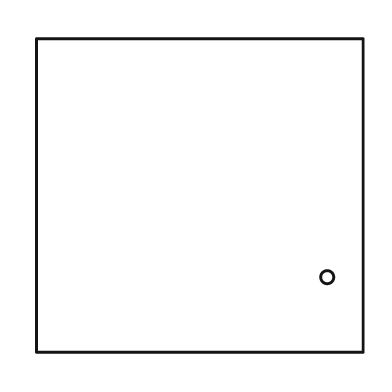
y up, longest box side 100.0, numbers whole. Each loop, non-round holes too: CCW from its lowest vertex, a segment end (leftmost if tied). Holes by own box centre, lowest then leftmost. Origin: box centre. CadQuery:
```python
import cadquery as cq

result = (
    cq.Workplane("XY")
    .moveTo(-50.0, -48.0)
    .lineTo(50.0, -48.0)
    .lineTo(50.0, 48.0)
    .lineTo(-50.0, 48.0)
    .close()
    .moveTo(39.0, -25.0)
    .circle(2.0)
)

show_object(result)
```